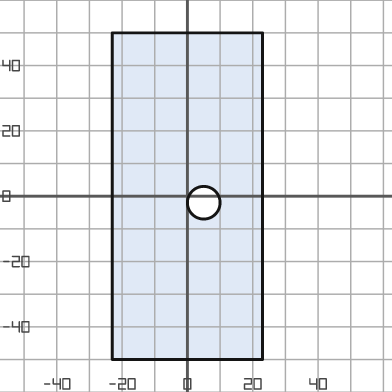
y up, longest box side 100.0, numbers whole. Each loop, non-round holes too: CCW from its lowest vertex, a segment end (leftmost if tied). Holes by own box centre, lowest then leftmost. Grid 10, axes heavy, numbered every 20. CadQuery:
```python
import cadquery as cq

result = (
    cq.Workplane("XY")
    .moveTo(-23.0, -50.0)
    .lineTo(23.0, -50.0)
    .lineTo(23.0, 50.0)
    .lineTo(-23.0, 50.0)
    .close()
    .moveTo(5.0, -2.0)
    .circle(5.0)
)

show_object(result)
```